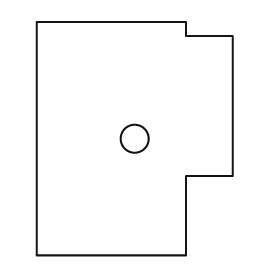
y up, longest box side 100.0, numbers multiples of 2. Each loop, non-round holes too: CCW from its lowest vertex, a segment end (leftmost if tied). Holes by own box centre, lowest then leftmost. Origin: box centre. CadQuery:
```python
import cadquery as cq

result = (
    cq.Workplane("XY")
    .moveTo(-42.0, -50.0)
    .lineTo(22.0, -50.0)
    .lineTo(22.0, -16.0)
    .lineTo(42.0, -16.0)
    .lineTo(42.0, 44.0)
    .lineTo(22.0, 44.0)
    .lineTo(22.0, 50.0)
    .lineTo(-42.0, 50.0)
    .close()
    .moveTo(0.0, 0.0)
    .circle(6.0)
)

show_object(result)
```